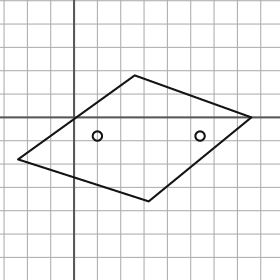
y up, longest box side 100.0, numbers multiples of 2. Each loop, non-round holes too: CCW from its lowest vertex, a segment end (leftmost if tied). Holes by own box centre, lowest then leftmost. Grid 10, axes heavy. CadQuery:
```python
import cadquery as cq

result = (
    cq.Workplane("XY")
    .moveTo(32.0, -36.0)
    .lineTo(76.0, 0.0)
    .lineTo(26.0, 18.0)
    .lineTo(-24.0, -18.0)
    .close()
    .moveTo(10.0, -8.0)
    .circle(2.0)
    .moveTo(54.0, -8.0)
    .circle(2.0)
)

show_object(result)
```